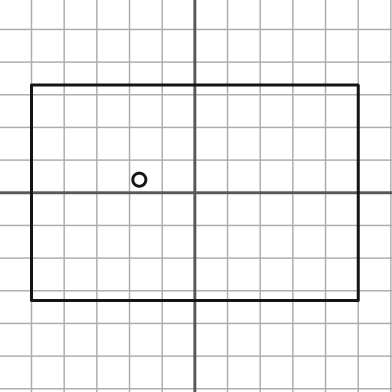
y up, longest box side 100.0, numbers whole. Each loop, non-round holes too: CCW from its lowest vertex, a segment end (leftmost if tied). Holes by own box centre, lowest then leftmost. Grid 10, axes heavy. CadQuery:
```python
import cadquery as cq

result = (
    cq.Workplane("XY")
    .moveTo(-50.0, -33.0)
    .lineTo(50.0, -33.0)
    .lineTo(50.0, 33.0)
    .lineTo(-50.0, 33.0)
    .close()
    .moveTo(-17.0, 4.0)
    .circle(2.0)
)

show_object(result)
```